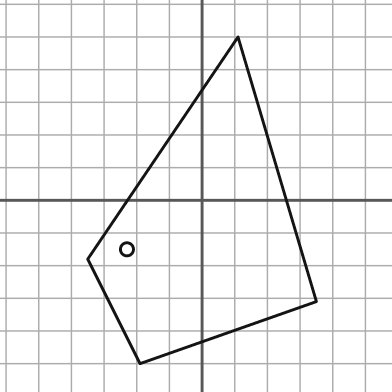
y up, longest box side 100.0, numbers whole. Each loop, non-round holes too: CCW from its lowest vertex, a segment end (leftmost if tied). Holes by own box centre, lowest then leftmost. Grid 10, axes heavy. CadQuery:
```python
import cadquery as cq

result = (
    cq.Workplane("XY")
    .moveTo(-19.0, -50.0)
    .lineTo(35.0, -31.0)
    .lineTo(11.0, 50.0)
    .lineTo(-35.0, -18.0)
    .close()
    .moveTo(-23.0, -15.0)
    .circle(2.0)
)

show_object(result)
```